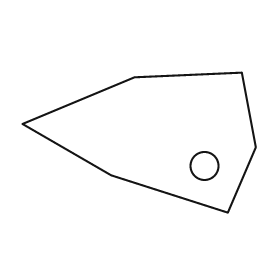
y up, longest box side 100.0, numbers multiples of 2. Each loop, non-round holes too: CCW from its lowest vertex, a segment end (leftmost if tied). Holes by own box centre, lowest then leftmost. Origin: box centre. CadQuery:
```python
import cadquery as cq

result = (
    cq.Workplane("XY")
    .moveTo(38.0, -30.0)
    .lineTo(50.0, -2.0)
    .lineTo(44.0, 30.0)
    .lineTo(-2.0, 28.0)
    .lineTo(-50.0, 8.0)
    .lineTo(-12.0, -14.0)
    .close()
    .moveTo(28.0, -10.0)
    .circle(6.0)
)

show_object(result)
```